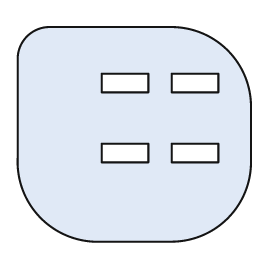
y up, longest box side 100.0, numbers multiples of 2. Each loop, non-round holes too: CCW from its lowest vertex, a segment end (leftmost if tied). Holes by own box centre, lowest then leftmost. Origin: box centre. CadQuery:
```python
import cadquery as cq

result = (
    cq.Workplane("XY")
    .moveTo(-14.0, -46.0)
    .lineTo(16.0, -46.0)
    .threePointArc((40.0, -36.0), (50.0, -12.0))
    .lineTo(50.0, 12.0)
    .threePointArc((40.0, 36.0), (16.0, 46.0))
    .lineTo(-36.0, 46.0)
    .threePointArc((-46.0, 42.0), (-50.0, 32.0))
    .lineTo(-50.0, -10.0)
    .threePointArc((-40.0, -36.0), (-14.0, -46.0))
    .close()
    .moveTo(-14.0, -12.0)
    .lineTo(6.0, -12.0)
    .lineTo(6.0, -4.0)
    .lineTo(-14.0, -4.0)
    .close()
    .moveTo(16.0, -12.0)
    .lineTo(36.0, -12.0)
    .lineTo(36.0, -4.0)
    .lineTo(16.0, -4.0)
    .close()
    .moveTo(-14.0, 18.0)
    .lineTo(6.0, 18.0)
    .lineTo(6.0, 26.0)
    .lineTo(-14.0, 26.0)
    .close()
    .moveTo(16.0, 18.0)
    .lineTo(36.0, 18.0)
    .lineTo(36.0, 26.0)
    .lineTo(16.0, 26.0)
    .close()
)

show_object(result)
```